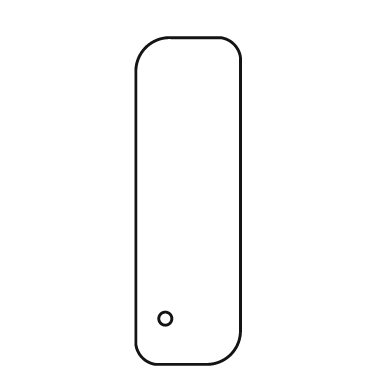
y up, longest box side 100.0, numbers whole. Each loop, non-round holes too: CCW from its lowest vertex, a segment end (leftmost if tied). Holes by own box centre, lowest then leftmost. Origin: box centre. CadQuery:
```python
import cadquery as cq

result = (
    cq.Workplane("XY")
    .moveTo(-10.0, -50.0)
    .lineTo(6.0, -50.0)
    .threePointArc((13.0, -47.0), (16.0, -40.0))
    .lineTo(16.0, 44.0)
    .threePointArc((14.0, 48.0), (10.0, 50.0))
    .lineTo(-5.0, 50.0)
    .threePointArc((-13.0, 47.0), (-16.0, 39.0))
    .lineTo(-16.0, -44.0)
    .threePointArc((-14.0, -48.0), (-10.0, -50.0))
    .close()
    .moveTo(-7.0, -36.0)
    .circle(2.0)
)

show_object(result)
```